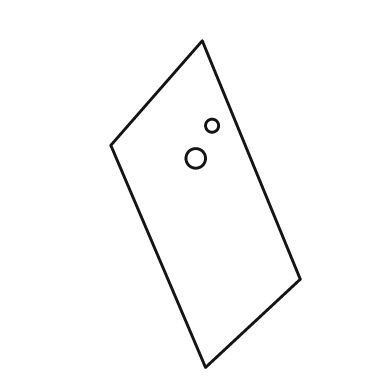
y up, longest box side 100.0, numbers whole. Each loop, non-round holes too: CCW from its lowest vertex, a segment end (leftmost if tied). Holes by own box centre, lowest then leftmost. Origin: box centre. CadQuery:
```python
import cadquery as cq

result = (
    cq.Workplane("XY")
    .moveTo(0.0, -50.0)
    .lineTo(29.0, -23.0)
    .lineTo(-1.0, 50.0)
    .lineTo(-29.0, 18.0)
    .close()
    .moveTo(-3.0, 14.0)
    .circle(3.0)
    .moveTo(2.0, 24.0)
    .circle(2.0)
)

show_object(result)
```